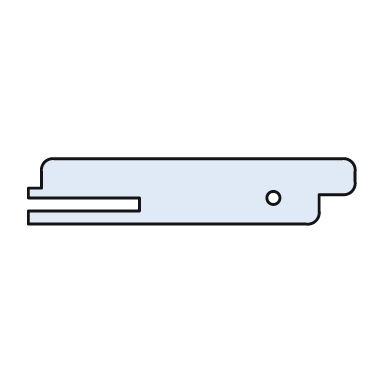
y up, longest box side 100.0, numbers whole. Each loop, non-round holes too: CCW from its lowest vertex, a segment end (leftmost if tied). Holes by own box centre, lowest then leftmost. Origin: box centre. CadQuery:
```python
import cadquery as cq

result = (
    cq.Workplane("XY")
    .moveTo(-50.0, -10.0)
    .lineTo(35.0, -10.0)
    .threePointArc((38.0, -9.0), (39.0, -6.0))
    .lineTo(39.0, -1.0)
    .lineTo(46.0, -1.0)
    .threePointArc((49.0, 0.0), (50.0, 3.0))
    .lineTo(50.0, 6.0)
    .threePointArc((49.0, 9.0), (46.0, 10.0))
    .lineTo(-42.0, 10.0)
    .threePointArc((-45.0, 9.0), (-46.0, 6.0))
    .lineTo(-46.0, 1.0)
    .lineTo(-50.0, 1.0)
    .lineTo(-50.0, -2.0)
    .lineTo(-16.0, -2.0)
    .lineTo(-16.0, -6.0)
    .lineTo(-50.0, -6.0)
    .close()
    .moveTo(25.0, -2.0)
    .circle(2.0)
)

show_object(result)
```